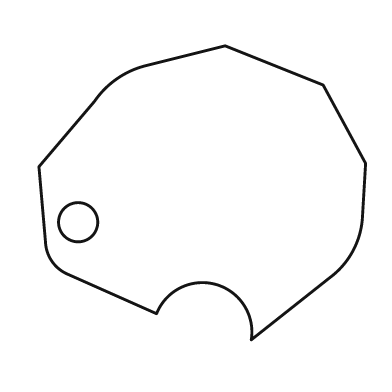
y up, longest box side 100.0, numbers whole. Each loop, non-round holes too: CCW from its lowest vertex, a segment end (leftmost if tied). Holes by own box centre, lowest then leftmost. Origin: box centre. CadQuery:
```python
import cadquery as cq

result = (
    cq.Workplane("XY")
    .moveTo(15.0, -45.0)
    .lineTo(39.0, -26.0)
    .threePointArc((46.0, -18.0), (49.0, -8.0))
    .lineTo(50.0, 9.0)
    .lineTo(37.0, 33.0)
    .lineTo(7.0, 45.0)
    .lineTo(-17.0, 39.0)
    .threePointArc((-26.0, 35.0), (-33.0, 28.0))
    .lineTo(-50.0, 8.0)
    .lineTo(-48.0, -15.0)
    .threePointArc((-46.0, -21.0), (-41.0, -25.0))
    .lineTo(-14.0, -37.0)
    .threePointArc((4.0, -28.0), (15.0, -45.0))
    .close()
    .moveTo(-38.0, -9.0)
    .circle(6.0)
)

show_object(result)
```